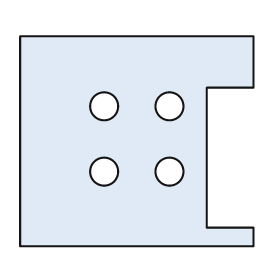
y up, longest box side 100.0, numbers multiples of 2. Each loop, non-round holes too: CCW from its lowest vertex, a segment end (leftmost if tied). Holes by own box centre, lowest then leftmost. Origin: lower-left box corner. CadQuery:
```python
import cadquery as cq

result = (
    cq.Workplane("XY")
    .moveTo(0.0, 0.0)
    .lineTo(100.0, 0.0)
    .lineTo(100.0, 8.0)
    .lineTo(80.0, 8.0)
    .lineTo(80.0, 68.0)
    .lineTo(100.0, 68.0)
    .lineTo(100.0, 90.0)
    .lineTo(0.0, 90.0)
    .close()
    .moveTo(36.0, 32.0)
    .circle(6.0)
    .moveTo(64.0, 32.0)
    .circle(6.0)
    .moveTo(36.0, 60.0)
    .circle(6.0)
    .moveTo(64.0, 60.0)
    .circle(6.0)
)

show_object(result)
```